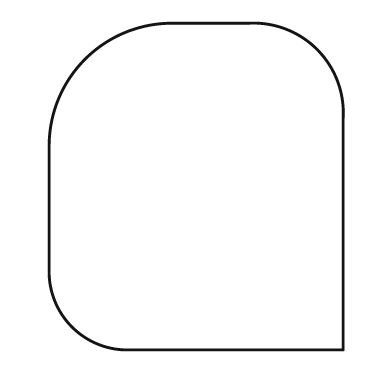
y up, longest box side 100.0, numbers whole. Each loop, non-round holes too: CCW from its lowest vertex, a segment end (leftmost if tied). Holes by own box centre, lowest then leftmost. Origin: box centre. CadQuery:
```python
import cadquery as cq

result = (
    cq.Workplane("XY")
    .moveTo(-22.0, -50.0)
    .lineTo(45.0, -50.0)
    .lineTo(45.0, 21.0)
    .threePointArc((37.0, 42.0), (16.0, 50.0))
    .lineTo(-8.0, 50.0)
    .threePointArc((-34.0, 39.0), (-45.0, 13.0))
    .lineTo(-45.0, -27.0)
    .threePointArc((-38.0, -43.0), (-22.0, -50.0))
    .close()
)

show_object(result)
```